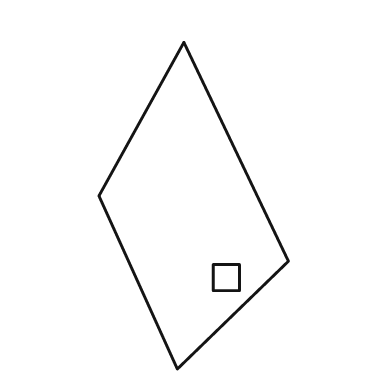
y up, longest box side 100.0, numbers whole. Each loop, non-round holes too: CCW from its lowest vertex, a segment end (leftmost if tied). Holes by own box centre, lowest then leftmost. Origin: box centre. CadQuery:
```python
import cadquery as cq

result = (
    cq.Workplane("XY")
    .moveTo(-5.0, -50.0)
    .lineTo(29.0, -17.0)
    .lineTo(-3.0, 50.0)
    .lineTo(-29.0, 3.0)
    .close()
    .moveTo(6.0, -26.0)
    .lineTo(14.0, -26.0)
    .lineTo(14.0, -18.0)
    .lineTo(6.0, -18.0)
    .close()
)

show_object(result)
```